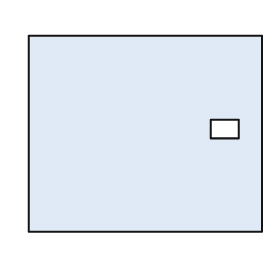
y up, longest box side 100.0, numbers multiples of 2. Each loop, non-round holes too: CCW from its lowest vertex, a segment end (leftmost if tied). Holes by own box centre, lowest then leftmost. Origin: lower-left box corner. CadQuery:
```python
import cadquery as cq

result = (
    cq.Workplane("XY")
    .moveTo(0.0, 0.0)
    .lineTo(100.0, 0.0)
    .lineTo(100.0, 84.0)
    .lineTo(0.0, 84.0)
    .close()
    .moveTo(78.0, 40.0)
    .lineTo(90.0, 40.0)
    .lineTo(90.0, 48.0)
    .lineTo(78.0, 48.0)
    .close()
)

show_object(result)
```